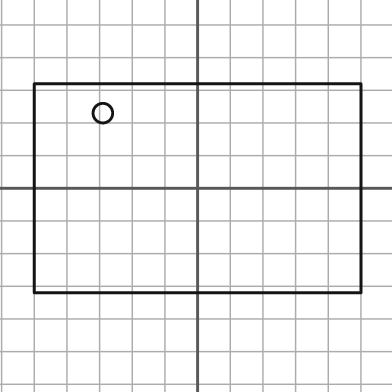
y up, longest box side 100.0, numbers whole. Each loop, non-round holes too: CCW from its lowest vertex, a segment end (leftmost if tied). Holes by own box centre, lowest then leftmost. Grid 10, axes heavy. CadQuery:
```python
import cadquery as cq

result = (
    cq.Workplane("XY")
    .moveTo(-50.0, -32.0)
    .lineTo(50.0, -32.0)
    .lineTo(50.0, 32.0)
    .lineTo(-50.0, 32.0)
    .close()
    .moveTo(-29.0, 23.0)
    .circle(3.0)
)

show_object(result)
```